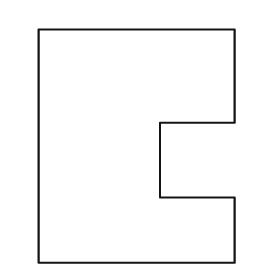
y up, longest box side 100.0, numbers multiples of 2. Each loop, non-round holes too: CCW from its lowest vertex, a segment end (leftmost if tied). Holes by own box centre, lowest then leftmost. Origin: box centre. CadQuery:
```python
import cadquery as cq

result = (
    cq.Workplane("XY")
    .moveTo(-42.0, -50.0)
    .lineTo(42.0, -50.0)
    .lineTo(42.0, -22.0)
    .lineTo(10.0, -22.0)
    .lineTo(10.0, 10.0)
    .lineTo(42.0, 10.0)
    .lineTo(42.0, 50.0)
    .lineTo(-42.0, 50.0)
    .close()
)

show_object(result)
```